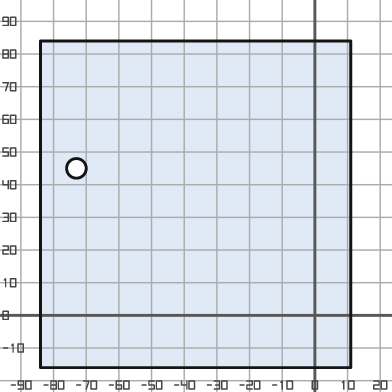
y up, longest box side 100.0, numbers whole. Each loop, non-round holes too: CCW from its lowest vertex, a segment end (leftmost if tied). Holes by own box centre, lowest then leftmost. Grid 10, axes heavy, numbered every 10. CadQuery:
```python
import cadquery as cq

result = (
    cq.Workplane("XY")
    .moveTo(-84.0, -16.0)
    .lineTo(11.0, -16.0)
    .lineTo(11.0, 84.0)
    .lineTo(-84.0, 84.0)
    .close()
    .moveTo(-73.0, 45.0)
    .circle(3.0)
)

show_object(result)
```